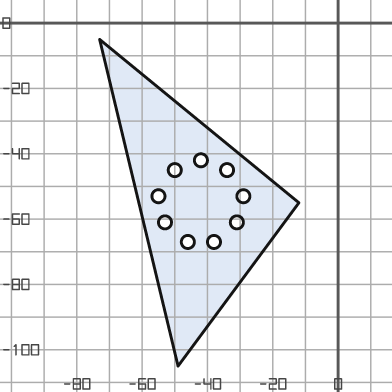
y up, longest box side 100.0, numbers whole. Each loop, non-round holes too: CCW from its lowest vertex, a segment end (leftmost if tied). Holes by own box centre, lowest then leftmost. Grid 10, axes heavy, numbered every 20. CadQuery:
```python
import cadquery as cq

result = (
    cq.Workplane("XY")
    .moveTo(-49.0, -105.0)
    .lineTo(-12.0, -55.0)
    .lineTo(-73.0, -5.0)
    .close()
    .moveTo(-46.0, -67.0)
    .circle(2.0)
    .moveTo(-38.0, -67.0)
    .circle(2.0)
    .moveTo(-53.0, -61.0)
    .circle(2.0)
    .moveTo(-31.0, -61.0)
    .circle(2.0)
    .moveTo(-55.0, -53.0)
    .circle(2.0)
    .moveTo(-29.0, -53.0)
    .circle(2.0)
    .moveTo(-50.0, -45.0)
    .circle(2.0)
    .moveTo(-34.0, -45.0)
    .circle(2.0)
    .moveTo(-42.0, -42.0)
    .circle(2.0)
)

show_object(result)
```